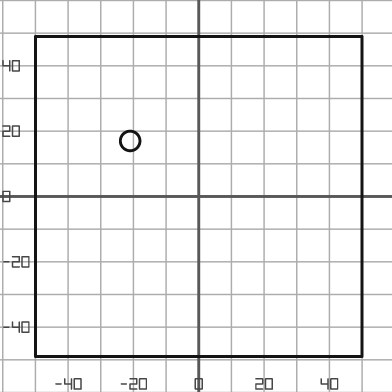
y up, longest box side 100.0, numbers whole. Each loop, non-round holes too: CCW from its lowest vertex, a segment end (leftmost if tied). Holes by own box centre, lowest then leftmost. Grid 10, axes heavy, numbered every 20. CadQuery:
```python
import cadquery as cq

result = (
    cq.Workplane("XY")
    .moveTo(-50.0, -49.0)
    .lineTo(50.0, -49.0)
    .lineTo(50.0, 49.0)
    .lineTo(-50.0, 49.0)
    .close()
    .moveTo(-21.0, 17.0)
    .circle(3.0)
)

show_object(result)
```